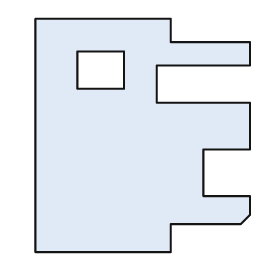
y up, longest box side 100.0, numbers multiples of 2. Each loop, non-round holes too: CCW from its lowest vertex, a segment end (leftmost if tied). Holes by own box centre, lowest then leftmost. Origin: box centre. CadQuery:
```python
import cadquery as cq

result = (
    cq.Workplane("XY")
    .moveTo(-46.0, -50.0)
    .lineTo(12.0, -50.0)
    .lineTo(12.0, -38.0)
    .lineTo(42.0, -38.0)
    .lineTo(46.0, -34.0)
    .lineTo(46.0, -26.0)
    .lineTo(26.0, -26.0)
    .lineTo(26.0, -6.0)
    .lineTo(46.0, -6.0)
    .lineTo(46.0, 14.0)
    .lineTo(6.0, 14.0)
    .lineTo(6.0, 30.0)
    .lineTo(46.0, 30.0)
    .lineTo(46.0, 40.0)
    .lineTo(12.0, 40.0)
    .lineTo(12.0, 50.0)
    .lineTo(-46.0, 50.0)
    .close()
    .moveTo(-28.0, 20.0)
    .lineTo(-8.0, 20.0)
    .lineTo(-8.0, 36.0)
    .lineTo(-28.0, 36.0)
    .close()
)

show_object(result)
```